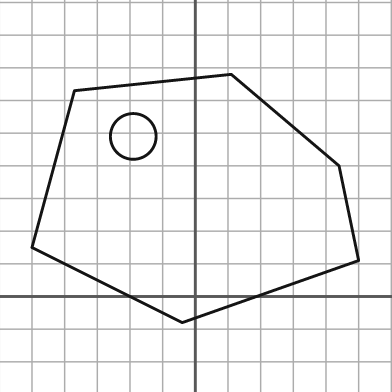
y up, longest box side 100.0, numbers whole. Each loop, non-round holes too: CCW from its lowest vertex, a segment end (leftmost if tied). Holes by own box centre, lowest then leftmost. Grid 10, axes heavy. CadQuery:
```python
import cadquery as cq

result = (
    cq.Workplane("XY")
    .moveTo(-4.0, -8.0)
    .lineTo(50.0, 11.0)
    .lineTo(44.0, 40.0)
    .lineTo(11.0, 68.0)
    .lineTo(-37.0, 63.0)
    .lineTo(-50.0, 15.0)
    .close()
    .moveTo(-19.0, 49.0)
    .circle(7.0)
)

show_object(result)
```